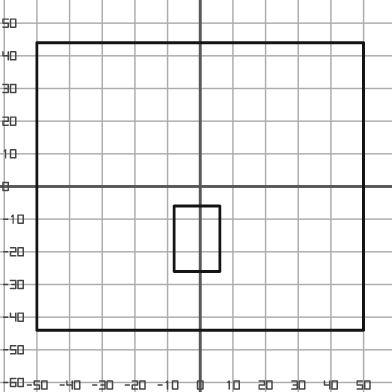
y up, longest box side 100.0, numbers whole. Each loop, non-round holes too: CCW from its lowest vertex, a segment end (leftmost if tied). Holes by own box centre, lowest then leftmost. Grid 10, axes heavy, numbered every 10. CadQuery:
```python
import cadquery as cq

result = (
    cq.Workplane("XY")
    .moveTo(-50.0, -44.0)
    .lineTo(50.0, -44.0)
    .lineTo(50.0, 44.0)
    .lineTo(-50.0, 44.0)
    .close()
    .moveTo(-8.0, -26.0)
    .lineTo(6.0, -26.0)
    .lineTo(6.0, -6.0)
    .lineTo(-8.0, -6.0)
    .close()
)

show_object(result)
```